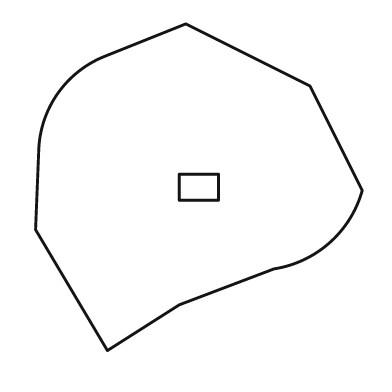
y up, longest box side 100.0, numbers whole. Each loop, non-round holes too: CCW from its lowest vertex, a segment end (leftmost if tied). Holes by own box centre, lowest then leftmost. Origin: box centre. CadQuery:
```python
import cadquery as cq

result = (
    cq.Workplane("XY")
    .moveTo(-28.0, -50.0)
    .lineTo(-6.0, -36.0)
    .lineTo(23.0, -25.0)
    .threePointArc((40.0, -17.0), (50.0, -1.0))
    .lineTo(34.0, 31.0)
    .lineTo(-4.0, 50.0)
    .lineTo(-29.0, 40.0)
    .threePointArc((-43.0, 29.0), (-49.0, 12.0))
    .lineTo(-50.0, -13.0)
    .close()
    .moveTo(-6.0, -4.0)
    .lineTo(6.0, -4.0)
    .lineTo(6.0, 4.0)
    .lineTo(-6.0, 4.0)
    .close()
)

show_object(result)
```